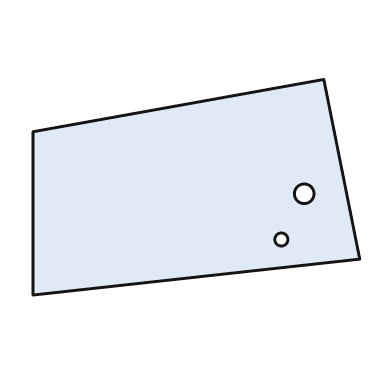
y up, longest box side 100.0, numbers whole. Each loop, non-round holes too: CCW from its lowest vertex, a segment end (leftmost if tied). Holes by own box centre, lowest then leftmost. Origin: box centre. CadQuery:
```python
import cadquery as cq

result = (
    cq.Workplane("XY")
    .moveTo(-50.0, -33.0)
    .lineTo(50.0, -22.0)
    .lineTo(39.0, 33.0)
    .lineTo(-50.0, 17.0)
    .close()
    .moveTo(26.0, -16.0)
    .circle(2.0)
    .moveTo(33.0, -2.0)
    .circle(3.0)
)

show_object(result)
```